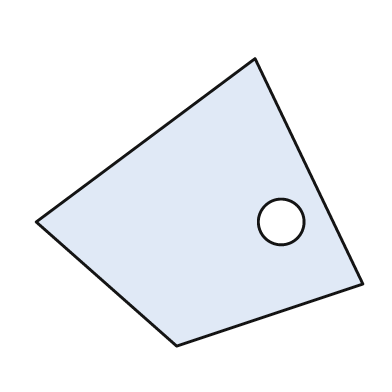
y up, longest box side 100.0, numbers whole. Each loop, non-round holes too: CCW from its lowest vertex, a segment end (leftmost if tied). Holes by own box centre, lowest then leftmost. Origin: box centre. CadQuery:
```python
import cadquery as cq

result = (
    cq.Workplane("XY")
    .moveTo(-7.0, -44.0)
    .lineTo(50.0, -25.0)
    .lineTo(17.0, 44.0)
    .lineTo(-50.0, -6.0)
    .close()
    .moveTo(25.0, -6.0)
    .circle(7.0)
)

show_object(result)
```